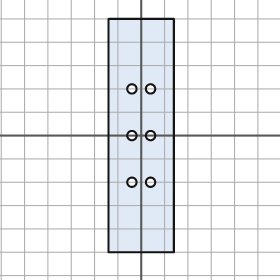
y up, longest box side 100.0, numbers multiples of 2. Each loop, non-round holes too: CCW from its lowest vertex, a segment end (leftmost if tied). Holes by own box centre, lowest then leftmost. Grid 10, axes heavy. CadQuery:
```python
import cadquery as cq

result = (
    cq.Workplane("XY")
    .moveTo(-14.0, -50.0)
    .lineTo(14.0, -50.0)
    .lineTo(14.0, 50.0)
    .lineTo(-14.0, 50.0)
    .close()
    .moveTo(-4.0, -20.0)
    .circle(2.0)
    .moveTo(4.0, -20.0)
    .circle(2.0)
    .moveTo(-4.0, 0.0)
    .circle(2.0)
    .moveTo(4.0, 0.0)
    .circle(2.0)
    .moveTo(-4.0, 20.0)
    .circle(2.0)
    .moveTo(4.0, 20.0)
    .circle(2.0)
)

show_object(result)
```